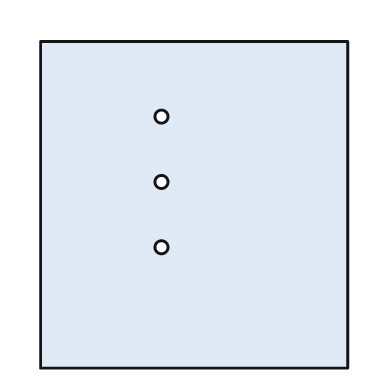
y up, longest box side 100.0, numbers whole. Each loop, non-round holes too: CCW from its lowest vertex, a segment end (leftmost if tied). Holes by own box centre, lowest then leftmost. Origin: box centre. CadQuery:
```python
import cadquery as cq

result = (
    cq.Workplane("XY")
    .moveTo(-47.0, -50.0)
    .lineTo(47.0, -50.0)
    .lineTo(47.0, 50.0)
    .lineTo(-47.0, 50.0)
    .close()
    .moveTo(-10.0, -13.0)
    .circle(2.0)
    .moveTo(-10.0, 7.0)
    .circle(2.0)
    .moveTo(-10.0, 27.0)
    .circle(2.0)
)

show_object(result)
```